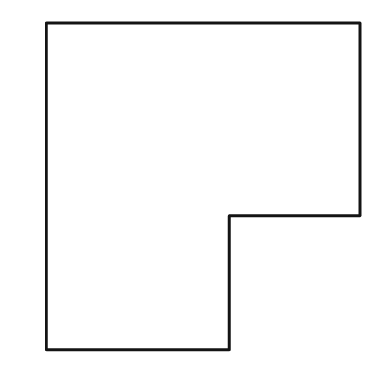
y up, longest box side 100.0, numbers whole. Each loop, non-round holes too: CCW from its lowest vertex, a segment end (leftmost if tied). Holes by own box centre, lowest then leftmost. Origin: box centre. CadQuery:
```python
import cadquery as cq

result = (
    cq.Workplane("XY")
    .moveTo(-48.0, -50.0)
    .lineTo(8.0, -50.0)
    .lineTo(8.0, -9.0)
    .lineTo(48.0, -9.0)
    .lineTo(48.0, 50.0)
    .lineTo(-48.0, 50.0)
    .close()
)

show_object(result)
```